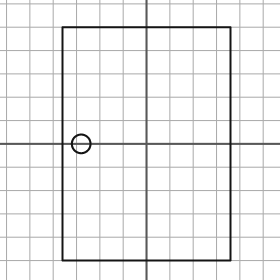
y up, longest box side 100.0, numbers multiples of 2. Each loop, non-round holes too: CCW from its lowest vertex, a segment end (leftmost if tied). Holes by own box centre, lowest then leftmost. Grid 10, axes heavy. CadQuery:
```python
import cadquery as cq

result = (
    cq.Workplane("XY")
    .moveTo(-36.0, -50.0)
    .lineTo(36.0, -50.0)
    .lineTo(36.0, 50.0)
    .lineTo(-36.0, 50.0)
    .close()
    .moveTo(-28.0, 0.0)
    .circle(4.0)
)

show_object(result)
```